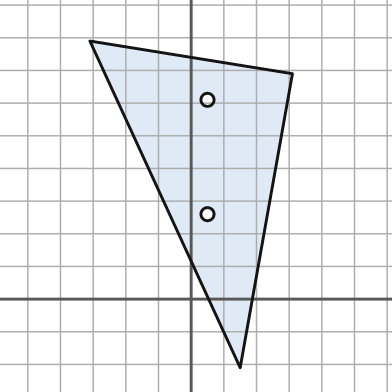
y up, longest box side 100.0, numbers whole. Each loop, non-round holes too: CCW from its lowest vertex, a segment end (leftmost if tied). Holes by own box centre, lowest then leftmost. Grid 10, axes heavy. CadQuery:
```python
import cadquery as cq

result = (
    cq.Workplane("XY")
    .moveTo(15.0, -21.0)
    .lineTo(31.0, 69.0)
    .lineTo(-31.0, 79.0)
    .close()
    .moveTo(5.0, 26.0)
    .circle(2.0)
    .moveTo(5.0, 61.0)
    .circle(2.0)
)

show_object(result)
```